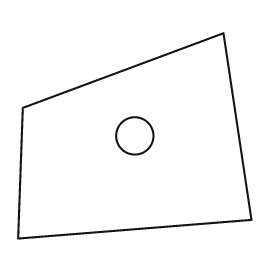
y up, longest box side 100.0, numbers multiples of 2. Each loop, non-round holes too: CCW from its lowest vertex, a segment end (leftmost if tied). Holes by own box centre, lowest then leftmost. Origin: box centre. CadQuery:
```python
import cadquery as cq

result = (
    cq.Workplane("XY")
    .moveTo(-50.0, -44.0)
    .lineTo(50.0, -36.0)
    .lineTo(38.0, 44.0)
    .lineTo(-48.0, 12.0)
    .close()
    .moveTo(0.0, 0.0)
    .circle(8.0)
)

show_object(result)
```